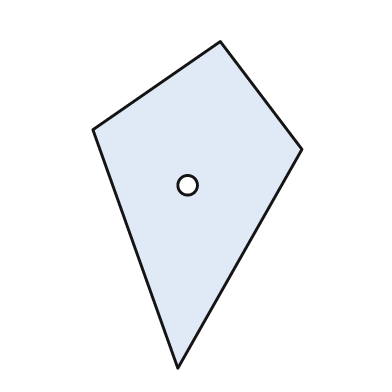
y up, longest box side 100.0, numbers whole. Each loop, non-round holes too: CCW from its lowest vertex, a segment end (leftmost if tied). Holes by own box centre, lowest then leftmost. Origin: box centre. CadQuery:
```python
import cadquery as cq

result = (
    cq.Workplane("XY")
    .moveTo(-6.0, -50.0)
    .lineTo(32.0, 17.0)
    .lineTo(7.0, 50.0)
    .lineTo(-32.0, 23.0)
    .close()
    .moveTo(-3.0, 6.0)
    .circle(3.0)
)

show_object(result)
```